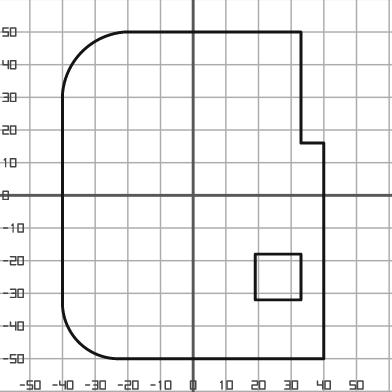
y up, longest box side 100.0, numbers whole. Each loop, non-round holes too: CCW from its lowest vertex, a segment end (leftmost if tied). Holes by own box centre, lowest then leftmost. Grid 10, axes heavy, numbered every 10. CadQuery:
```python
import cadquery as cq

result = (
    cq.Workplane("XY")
    .moveTo(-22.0, -50.0)
    .lineTo(40.0, -50.0)
    .lineTo(40.0, 16.0)
    .lineTo(33.0, 16.0)
    .lineTo(33.0, 50.0)
    .lineTo(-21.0, 50.0)
    .threePointArc((-34.0, 44.0), (-40.0, 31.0))
    .lineTo(-40.0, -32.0)
    .threePointArc((-35.0, -45.0), (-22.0, -50.0))
    .close()
    .moveTo(19.0, -32.0)
    .lineTo(33.0, -32.0)
    .lineTo(33.0, -18.0)
    .lineTo(19.0, -18.0)
    .close()
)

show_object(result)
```